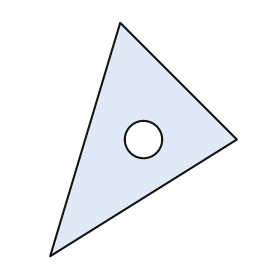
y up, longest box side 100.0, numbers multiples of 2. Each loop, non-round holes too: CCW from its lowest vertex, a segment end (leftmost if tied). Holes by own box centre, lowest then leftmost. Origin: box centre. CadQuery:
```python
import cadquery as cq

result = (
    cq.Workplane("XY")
    .moveTo(-40.0, -50.0)
    .lineTo(40.0, 0.0)
    .lineTo(-10.0, 50.0)
    .close()
    .moveTo(0.0, 0.0)
    .circle(8.0)
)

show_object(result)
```